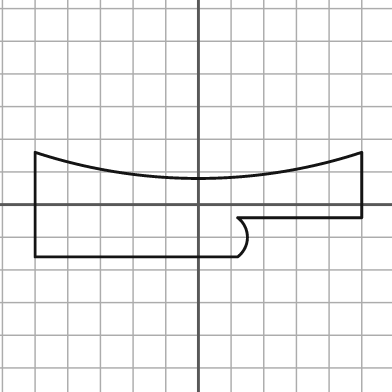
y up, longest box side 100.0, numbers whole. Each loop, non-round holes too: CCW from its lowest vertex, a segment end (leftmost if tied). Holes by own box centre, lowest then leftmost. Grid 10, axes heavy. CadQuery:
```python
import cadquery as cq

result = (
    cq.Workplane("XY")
    .moveTo(-50.0, -16.0)
    .lineTo(12.0, -16.0)
    .threePointArc((15.0, -10.0), (12.0, -4.0))
    .lineTo(50.0, -4.0)
    .lineTo(50.0, 16.0)
    .threePointArc((0.0, 8.0), (-50.0, 16.0))
    .close()
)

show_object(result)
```